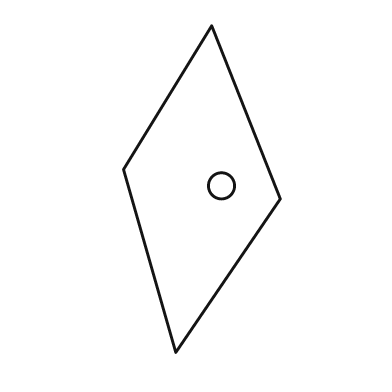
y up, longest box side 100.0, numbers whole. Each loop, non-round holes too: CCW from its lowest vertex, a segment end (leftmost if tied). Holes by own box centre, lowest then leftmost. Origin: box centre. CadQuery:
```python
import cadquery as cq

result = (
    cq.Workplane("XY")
    .moveTo(-8.0, -50.0)
    .lineTo(24.0, -3.0)
    .lineTo(3.0, 50.0)
    .lineTo(-24.0, 6.0)
    .close()
    .moveTo(6.0, 1.0)
    .circle(4.0)
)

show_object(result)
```